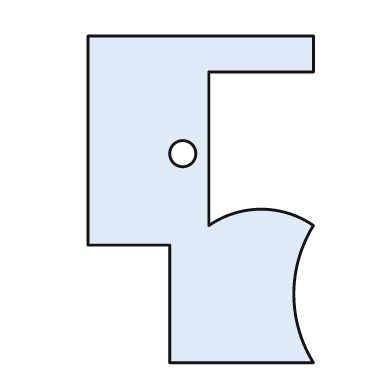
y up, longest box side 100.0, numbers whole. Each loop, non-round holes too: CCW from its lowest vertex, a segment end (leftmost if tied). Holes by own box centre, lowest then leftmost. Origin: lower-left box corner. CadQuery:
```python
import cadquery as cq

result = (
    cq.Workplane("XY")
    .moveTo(25.0, 0.0)
    .lineTo(69.0, 0.0)
    .threePointArc((63.0, 21.0), (69.0, 42.0))
    .threePointArc((53.0, 47.0), (37.0, 42.0))
    .lineTo(37.0, 89.0)
    .lineTo(69.0, 89.0)
    .lineTo(69.0, 100.0)
    .lineTo(0.0, 100.0)
    .lineTo(0.0, 36.0)
    .lineTo(25.0, 36.0)
    .close()
    .moveTo(29.0, 64.0)
    .circle(4.0)
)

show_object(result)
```